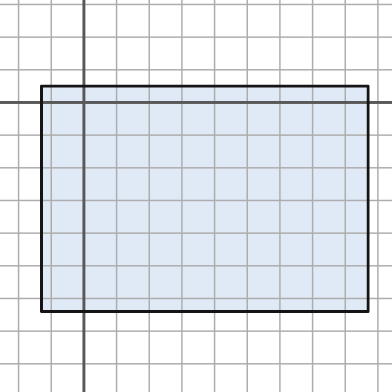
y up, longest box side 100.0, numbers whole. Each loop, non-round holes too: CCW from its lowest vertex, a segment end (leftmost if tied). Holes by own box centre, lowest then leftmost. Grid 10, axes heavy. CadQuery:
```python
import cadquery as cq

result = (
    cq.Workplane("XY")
    .moveTo(-13.0, -64.0)
    .lineTo(87.0, -64.0)
    .lineTo(87.0, 5.0)
    .lineTo(-13.0, 5.0)
    .close()
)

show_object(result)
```